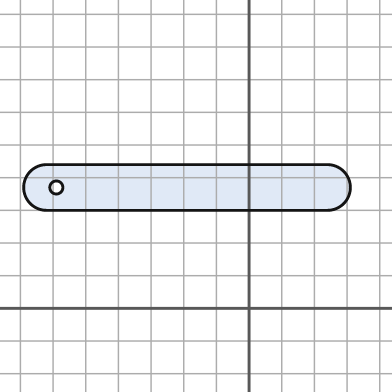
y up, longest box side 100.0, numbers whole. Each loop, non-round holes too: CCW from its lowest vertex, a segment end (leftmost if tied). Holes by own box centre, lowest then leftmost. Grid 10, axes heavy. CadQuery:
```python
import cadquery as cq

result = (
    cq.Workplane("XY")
    .moveTo(-62.0, 30.0)
    .lineTo(24.0, 30.0)
    .threePointArc((31.0, 37.0), (24.0, 44.0))
    .lineTo(-62.0, 44.0)
    .threePointArc((-69.0, 37.0), (-62.0, 30.0))
    .close()
    .moveTo(-59.0, 37.0)
    .circle(2.0)
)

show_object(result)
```